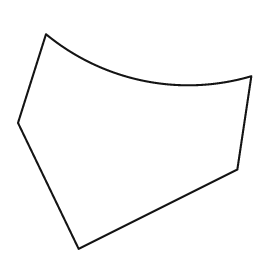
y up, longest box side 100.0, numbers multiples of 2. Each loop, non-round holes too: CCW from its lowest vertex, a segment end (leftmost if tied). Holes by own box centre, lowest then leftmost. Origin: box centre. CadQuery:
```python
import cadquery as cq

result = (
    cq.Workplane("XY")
    .moveTo(-24.0, -46.0)
    .lineTo(44.0, -12.0)
    .lineTo(50.0, 28.0)
    .threePointArc((4.0, 26.0), (-38.0, 46.0))
    .lineTo(-50.0, 8.0)
    .close()
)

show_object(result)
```